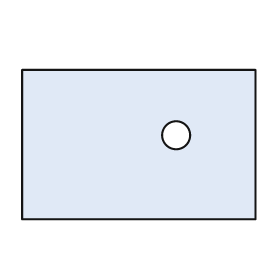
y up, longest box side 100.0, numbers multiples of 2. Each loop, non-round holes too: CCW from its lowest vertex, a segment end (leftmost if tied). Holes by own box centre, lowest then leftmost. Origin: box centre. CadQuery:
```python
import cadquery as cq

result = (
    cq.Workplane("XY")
    .moveTo(-50.0, -32.0)
    .lineTo(50.0, -32.0)
    .lineTo(50.0, 32.0)
    .lineTo(-50.0, 32.0)
    .close()
    .moveTo(16.0, 4.0)
    .circle(6.0)
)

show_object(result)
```